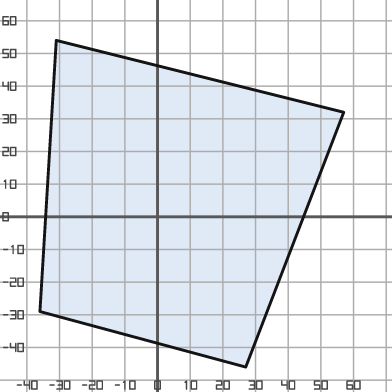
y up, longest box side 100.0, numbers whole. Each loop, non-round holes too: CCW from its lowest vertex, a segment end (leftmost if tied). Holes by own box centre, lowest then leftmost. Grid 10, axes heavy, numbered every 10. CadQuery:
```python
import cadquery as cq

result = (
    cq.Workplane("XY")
    .moveTo(27.0, -46.0)
    .lineTo(57.0, 32.0)
    .lineTo(-31.0, 54.0)
    .lineTo(-36.0, -29.0)
    .close()
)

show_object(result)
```